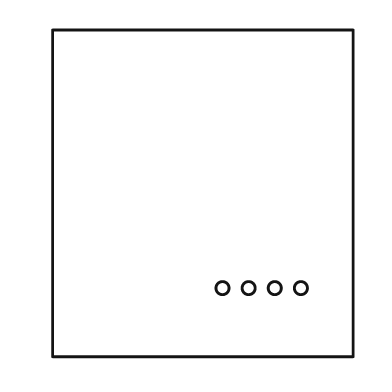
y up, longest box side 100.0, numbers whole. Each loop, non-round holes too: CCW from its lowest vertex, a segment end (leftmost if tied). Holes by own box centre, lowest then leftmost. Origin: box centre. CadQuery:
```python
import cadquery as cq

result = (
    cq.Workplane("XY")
    .moveTo(-46.0, -50.0)
    .lineTo(46.0, -50.0)
    .lineTo(46.0, 50.0)
    .lineTo(-46.0, 50.0)
    .close()
    .moveTo(6.0, -29.0)
    .circle(2.0)
    .moveTo(14.0, -29.0)
    .circle(2.0)
    .moveTo(22.0, -29.0)
    .circle(2.0)
    .moveTo(30.0, -29.0)
    .circle(2.0)
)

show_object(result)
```